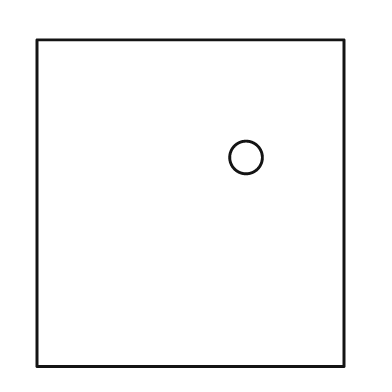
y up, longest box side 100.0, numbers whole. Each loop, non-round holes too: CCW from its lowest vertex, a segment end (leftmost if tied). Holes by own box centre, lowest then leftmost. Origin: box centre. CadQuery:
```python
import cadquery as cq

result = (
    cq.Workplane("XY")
    .moveTo(-47.0, -50.0)
    .lineTo(47.0, -50.0)
    .lineTo(47.0, 50.0)
    .lineTo(-47.0, 50.0)
    .close()
    .moveTo(17.0, 14.0)
    .circle(5.0)
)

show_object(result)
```